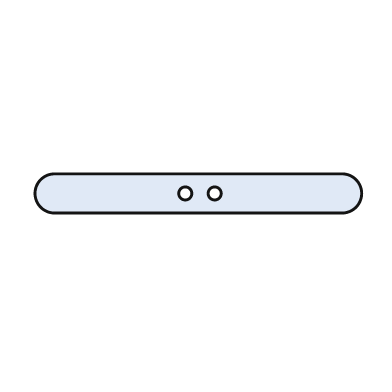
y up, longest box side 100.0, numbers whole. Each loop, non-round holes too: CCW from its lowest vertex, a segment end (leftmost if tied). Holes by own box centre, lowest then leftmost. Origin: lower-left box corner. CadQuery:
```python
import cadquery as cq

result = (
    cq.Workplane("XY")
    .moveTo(6.0, 0.0)
    .lineTo(94.0, 0.0)
    .threePointArc((100.0, 6.0), (94.0, 12.0))
    .lineTo(6.0, 12.0)
    .threePointArc((0.0, 6.0), (6.0, 0.0))
    .close()
    .moveTo(46.0, 6.0)
    .circle(2.0)
    .moveTo(55.0, 6.0)
    .circle(2.0)
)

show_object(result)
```